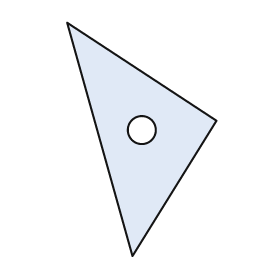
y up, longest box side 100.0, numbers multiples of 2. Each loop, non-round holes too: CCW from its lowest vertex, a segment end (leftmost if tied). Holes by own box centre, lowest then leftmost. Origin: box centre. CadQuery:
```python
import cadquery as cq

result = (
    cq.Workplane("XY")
    .moveTo(-4.0, -50.0)
    .lineTo(32.0, 8.0)
    .lineTo(-32.0, 50.0)
    .close()
    .moveTo(0.0, 4.0)
    .circle(6.0)
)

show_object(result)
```